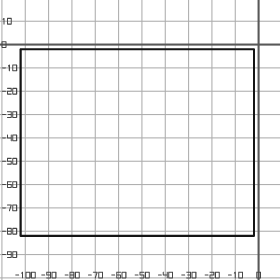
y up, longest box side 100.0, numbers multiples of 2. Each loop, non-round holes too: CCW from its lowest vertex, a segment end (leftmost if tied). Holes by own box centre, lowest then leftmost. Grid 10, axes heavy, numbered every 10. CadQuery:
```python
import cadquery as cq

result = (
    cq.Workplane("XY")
    .moveTo(-102.0, -82.0)
    .lineTo(-2.0, -82.0)
    .lineTo(-2.0, -2.0)
    .lineTo(-102.0, -2.0)
    .close()
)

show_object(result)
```